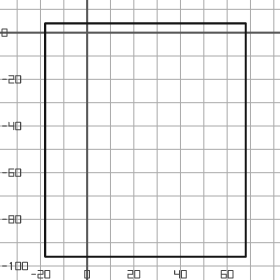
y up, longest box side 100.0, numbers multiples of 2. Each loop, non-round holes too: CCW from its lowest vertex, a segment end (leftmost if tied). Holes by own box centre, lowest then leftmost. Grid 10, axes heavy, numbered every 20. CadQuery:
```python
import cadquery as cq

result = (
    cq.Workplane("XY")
    .moveTo(-18.0, -96.0)
    .lineTo(68.0, -96.0)
    .lineTo(68.0, 4.0)
    .lineTo(-18.0, 4.0)
    .close()
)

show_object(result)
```